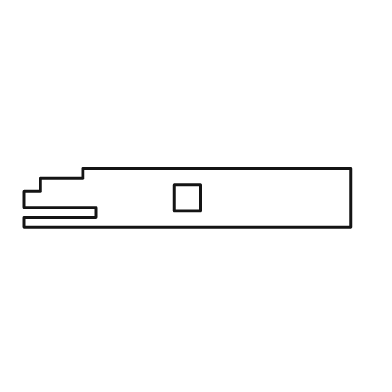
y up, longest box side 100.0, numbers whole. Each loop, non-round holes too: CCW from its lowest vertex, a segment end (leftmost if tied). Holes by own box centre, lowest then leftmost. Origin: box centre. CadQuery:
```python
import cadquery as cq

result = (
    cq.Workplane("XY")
    .moveTo(-50.0, -9.0)
    .lineTo(50.0, -9.0)
    .lineTo(50.0, 9.0)
    .lineTo(-32.0, 9.0)
    .lineTo(-32.0, 6.0)
    .lineTo(-45.0, 6.0)
    .lineTo(-45.0, 2.0)
    .lineTo(-50.0, 2.0)
    .lineTo(-50.0, -3.0)
    .lineTo(-28.0, -3.0)
    .lineTo(-28.0, -6.0)
    .lineTo(-50.0, -6.0)
    .close()
    .moveTo(-4.0, -4.0)
    .lineTo(4.0, -4.0)
    .lineTo(4.0, 4.0)
    .lineTo(-4.0, 4.0)
    .close()
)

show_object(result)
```